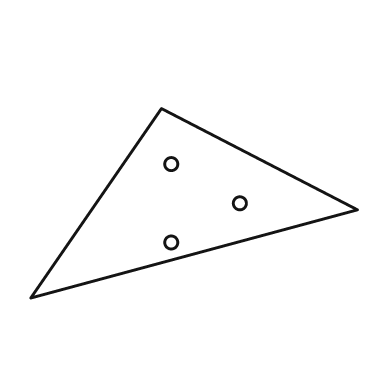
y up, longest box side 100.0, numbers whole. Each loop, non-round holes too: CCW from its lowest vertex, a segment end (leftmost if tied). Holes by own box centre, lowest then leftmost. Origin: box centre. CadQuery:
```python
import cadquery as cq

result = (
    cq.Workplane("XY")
    .moveTo(-50.0, -29.0)
    .lineTo(50.0, -2.0)
    .lineTo(-10.0, 29.0)
    .close()
    .moveTo(-7.0, -12.0)
    .circle(2.0)
    .moveTo(14.0, 0.0)
    .circle(2.0)
    .moveTo(-7.0, 12.0)
    .circle(2.0)
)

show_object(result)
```